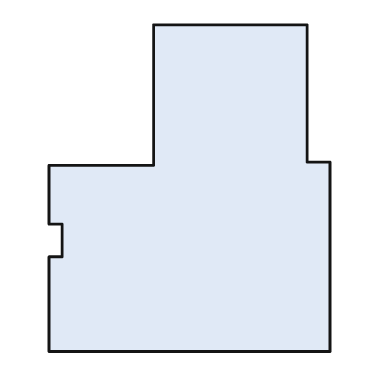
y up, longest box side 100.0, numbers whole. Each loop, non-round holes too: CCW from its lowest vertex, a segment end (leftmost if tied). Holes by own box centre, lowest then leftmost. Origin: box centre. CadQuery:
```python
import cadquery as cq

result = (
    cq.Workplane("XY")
    .moveTo(-43.0, -50.0)
    .lineTo(43.0, -50.0)
    .lineTo(43.0, 8.0)
    .lineTo(36.0, 8.0)
    .lineTo(36.0, 50.0)
    .lineTo(-11.0, 50.0)
    .lineTo(-11.0, 7.0)
    .lineTo(-43.0, 7.0)
    .lineTo(-43.0, -11.0)
    .lineTo(-39.0, -11.0)
    .lineTo(-39.0, -21.0)
    .lineTo(-43.0, -21.0)
    .close()
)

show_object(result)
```